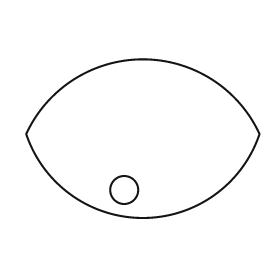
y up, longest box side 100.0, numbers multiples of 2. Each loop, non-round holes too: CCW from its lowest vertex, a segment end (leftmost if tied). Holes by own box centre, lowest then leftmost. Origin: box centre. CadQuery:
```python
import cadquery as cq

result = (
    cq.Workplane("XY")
    .moveTo(-50.0, 2.0)
    .threePointArc((0.0, -34.0), (50.0, 2.0))
    .threePointArc((0.0, 34.0), (-50.0, 2.0))
    .close()
    .moveTo(-8.0, -22.0)
    .circle(6.0)
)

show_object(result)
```